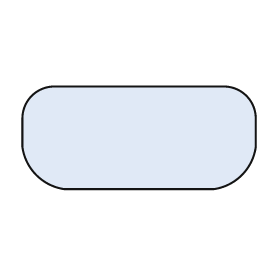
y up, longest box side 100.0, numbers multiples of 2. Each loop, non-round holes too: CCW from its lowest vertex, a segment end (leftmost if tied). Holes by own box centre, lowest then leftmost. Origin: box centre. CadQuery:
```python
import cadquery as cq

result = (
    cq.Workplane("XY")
    .moveTo(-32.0, -22.0)
    .lineTo(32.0, -22.0)
    .threePointArc((44.0, -16.0), (50.0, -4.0))
    .lineTo(50.0, 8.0)
    .threePointArc((46.0, 18.0), (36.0, 22.0))
    .lineTo(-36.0, 22.0)
    .threePointArc((-46.0, 18.0), (-50.0, 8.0))
    .lineTo(-50.0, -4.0)
    .threePointArc((-44.0, -16.0), (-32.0, -22.0))
    .close()
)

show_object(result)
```